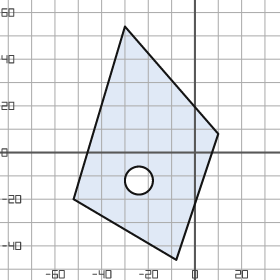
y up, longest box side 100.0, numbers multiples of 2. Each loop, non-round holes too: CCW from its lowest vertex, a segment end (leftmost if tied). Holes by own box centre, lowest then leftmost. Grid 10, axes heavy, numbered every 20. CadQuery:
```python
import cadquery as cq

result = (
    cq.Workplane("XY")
    .moveTo(-8.0, -46.0)
    .lineTo(10.0, 8.0)
    .lineTo(-30.0, 54.0)
    .lineTo(-52.0, -20.0)
    .close()
    .moveTo(-24.0, -12.0)
    .circle(6.0)
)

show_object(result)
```